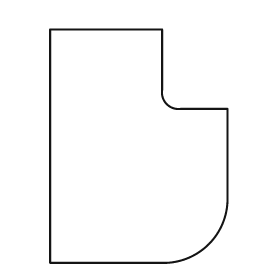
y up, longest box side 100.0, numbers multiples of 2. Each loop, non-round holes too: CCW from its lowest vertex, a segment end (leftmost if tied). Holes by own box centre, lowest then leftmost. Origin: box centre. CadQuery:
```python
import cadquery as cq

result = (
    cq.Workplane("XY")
    .moveTo(-38.0, -50.0)
    .lineTo(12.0, -50.0)
    .threePointArc((30.0, -42.0), (38.0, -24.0))
    .lineTo(38.0, 16.0)
    .lineTo(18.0, 16.0)
    .threePointArc((12.0, 18.0), (10.0, 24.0))
    .lineTo(10.0, 50.0)
    .lineTo(-38.0, 50.0)
    .close()
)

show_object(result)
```